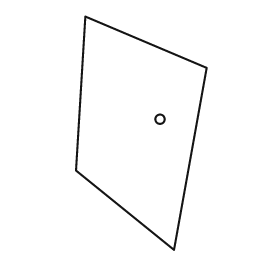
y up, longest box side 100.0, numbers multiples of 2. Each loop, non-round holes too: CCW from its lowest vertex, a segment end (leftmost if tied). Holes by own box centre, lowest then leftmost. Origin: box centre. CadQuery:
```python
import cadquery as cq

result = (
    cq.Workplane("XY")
    .moveTo(14.0, -50.0)
    .lineTo(28.0, 28.0)
    .lineTo(-24.0, 50.0)
    .lineTo(-28.0, -16.0)
    .close()
    .moveTo(8.0, 6.0)
    .circle(2.0)
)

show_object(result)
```